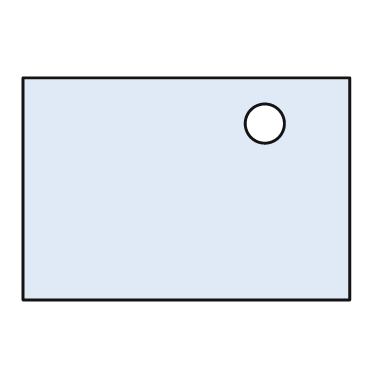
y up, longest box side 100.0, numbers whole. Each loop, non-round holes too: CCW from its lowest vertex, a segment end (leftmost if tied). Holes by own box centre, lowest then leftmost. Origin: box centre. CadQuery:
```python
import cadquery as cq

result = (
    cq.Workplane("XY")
    .moveTo(-50.0, -34.0)
    .lineTo(50.0, -34.0)
    .lineTo(50.0, 34.0)
    .lineTo(-50.0, 34.0)
    .close()
    .moveTo(24.0, 20.0)
    .circle(6.0)
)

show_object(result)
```